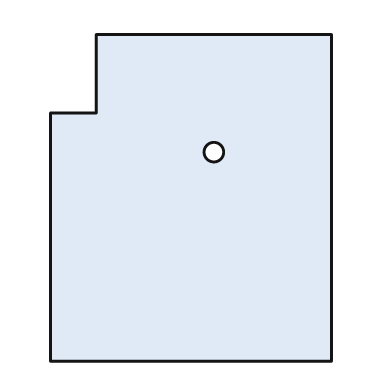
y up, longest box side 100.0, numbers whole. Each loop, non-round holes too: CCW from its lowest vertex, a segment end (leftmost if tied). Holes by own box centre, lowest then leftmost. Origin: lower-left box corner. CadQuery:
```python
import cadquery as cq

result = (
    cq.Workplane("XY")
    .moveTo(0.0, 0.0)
    .lineTo(86.0, 0.0)
    .lineTo(86.0, 100.0)
    .lineTo(14.0, 100.0)
    .lineTo(14.0, 76.0)
    .lineTo(0.0, 76.0)
    .close()
    .moveTo(50.0, 64.0)
    .circle(3.0)
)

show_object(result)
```